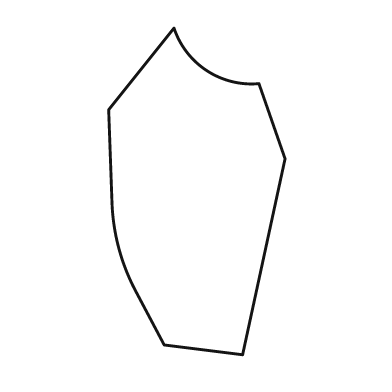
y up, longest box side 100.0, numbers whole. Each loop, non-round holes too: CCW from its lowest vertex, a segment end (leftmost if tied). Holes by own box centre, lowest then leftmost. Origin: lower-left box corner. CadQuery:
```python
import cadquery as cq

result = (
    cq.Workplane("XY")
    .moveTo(41.0, 0.0)
    .lineTo(54.0, 60.0)
    .lineTo(46.0, 83.0)
    .threePointArc((30.0, 87.0), (20.0, 100.0))
    .lineTo(0.0, 75.0)
    .lineTo(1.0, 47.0)
    .threePointArc((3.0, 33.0), (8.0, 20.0))
    .lineTo(17.0, 3.0)
    .close()
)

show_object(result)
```